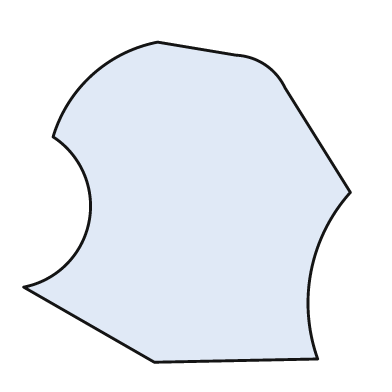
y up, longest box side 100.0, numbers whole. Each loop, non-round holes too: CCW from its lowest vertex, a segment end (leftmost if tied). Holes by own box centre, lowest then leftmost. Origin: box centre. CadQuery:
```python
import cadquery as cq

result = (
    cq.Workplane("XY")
    .moveTo(-10.0, -49.0)
    .lineTo(40.0, -48.0)
    .threePointArc((38.0, -21.0), (50.0, 3.0))
    .lineTo(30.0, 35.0)
    .threePointArc((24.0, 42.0), (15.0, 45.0))
    .lineTo(-9.0, 49.0)
    .threePointArc((-29.0, 39.0), (-41.0, 20.0))
    .threePointArc((-30.0, -6.0), (-50.0, -26.0))
    .close()
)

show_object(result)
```